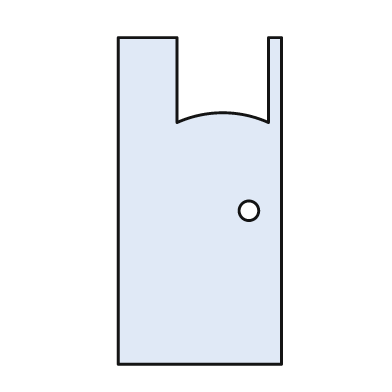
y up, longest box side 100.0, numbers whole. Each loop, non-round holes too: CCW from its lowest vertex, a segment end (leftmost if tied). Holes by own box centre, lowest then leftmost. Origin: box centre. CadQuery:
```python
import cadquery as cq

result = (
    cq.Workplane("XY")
    .moveTo(-25.0, -50.0)
    .lineTo(25.0, -50.0)
    .lineTo(25.0, 50.0)
    .lineTo(21.0, 50.0)
    .lineTo(21.0, 24.0)
    .threePointArc((7.0, 27.0), (-7.0, 24.0))
    .lineTo(-7.0, 50.0)
    .lineTo(-25.0, 50.0)
    .close()
    .moveTo(15.0, -3.0)
    .circle(3.0)
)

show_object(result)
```